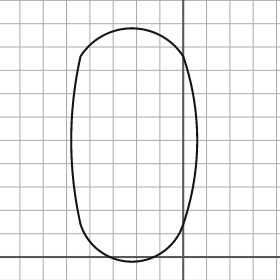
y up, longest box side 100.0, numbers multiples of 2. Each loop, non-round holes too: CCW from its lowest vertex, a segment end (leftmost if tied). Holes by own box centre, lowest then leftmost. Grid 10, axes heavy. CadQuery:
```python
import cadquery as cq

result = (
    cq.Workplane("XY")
    .moveTo(-44.0, 14.0)
    .threePointArc((-22.0, -2.0), (0.0, 14.0))
    .threePointArc((6.0, 50.0), (0.0, 86.0))
    .threePointArc((-22.0, 98.0), (-44.0, 86.0))
    .threePointArc((-48.0, 50.0), (-44.0, 14.0))
    .close()
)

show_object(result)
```